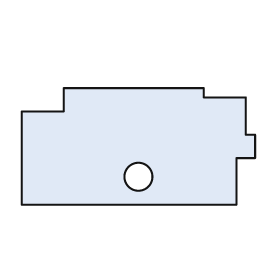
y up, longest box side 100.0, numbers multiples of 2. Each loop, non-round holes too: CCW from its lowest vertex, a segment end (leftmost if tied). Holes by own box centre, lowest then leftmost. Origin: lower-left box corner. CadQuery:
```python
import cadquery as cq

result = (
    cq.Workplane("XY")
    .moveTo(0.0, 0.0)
    .lineTo(92.0, 0.0)
    .lineTo(92.0, 20.0)
    .lineTo(100.0, 20.0)
    .lineTo(100.0, 30.0)
    .lineTo(96.0, 30.0)
    .lineTo(96.0, 46.0)
    .lineTo(78.0, 46.0)
    .lineTo(78.0, 50.0)
    .lineTo(18.0, 50.0)
    .lineTo(18.0, 40.0)
    .lineTo(0.0, 40.0)
    .close()
    .moveTo(50.0, 12.0)
    .circle(6.0)
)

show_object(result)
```